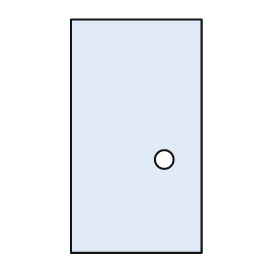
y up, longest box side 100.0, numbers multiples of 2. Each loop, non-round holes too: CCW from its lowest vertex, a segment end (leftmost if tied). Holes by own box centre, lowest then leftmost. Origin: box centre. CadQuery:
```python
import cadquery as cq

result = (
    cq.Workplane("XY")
    .moveTo(-28.0, -50.0)
    .lineTo(28.0, -50.0)
    .lineTo(28.0, 50.0)
    .lineTo(-28.0, 50.0)
    .close()
    .moveTo(12.0, -10.0)
    .circle(4.0)
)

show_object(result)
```